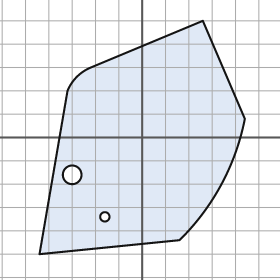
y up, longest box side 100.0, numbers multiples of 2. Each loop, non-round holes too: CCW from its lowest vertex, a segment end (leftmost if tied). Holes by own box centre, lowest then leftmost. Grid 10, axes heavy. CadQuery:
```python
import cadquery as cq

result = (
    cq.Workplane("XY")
    .moveTo(-44.0, -50.0)
    .lineTo(16.0, -44.0)
    .threePointArc((34.0, -20.0), (44.0, 8.0))
    .lineTo(26.0, 50.0)
    .lineTo(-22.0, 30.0)
    .threePointArc((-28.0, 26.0), (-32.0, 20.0))
    .close()
    .moveTo(-16.0, -34.0)
    .circle(2.0)
    .moveTo(-30.0, -16.0)
    .circle(4.0)
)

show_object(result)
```